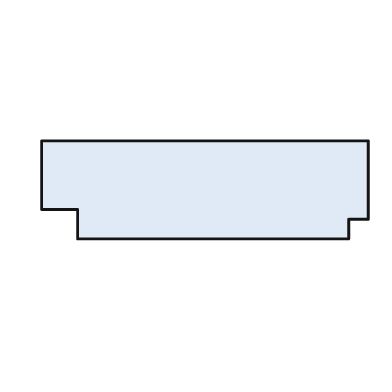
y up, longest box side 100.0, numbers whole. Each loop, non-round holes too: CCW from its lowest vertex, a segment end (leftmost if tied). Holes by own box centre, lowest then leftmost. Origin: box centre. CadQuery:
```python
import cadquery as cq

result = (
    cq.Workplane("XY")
    .moveTo(-39.0, -15.0)
    .lineTo(44.0, -15.0)
    .lineTo(44.0, -9.0)
    .lineTo(50.0, -9.0)
    .lineTo(50.0, 15.0)
    .lineTo(-50.0, 15.0)
    .lineTo(-50.0, -6.0)
    .lineTo(-39.0, -6.0)
    .close()
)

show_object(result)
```